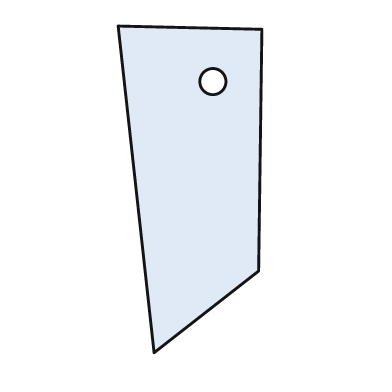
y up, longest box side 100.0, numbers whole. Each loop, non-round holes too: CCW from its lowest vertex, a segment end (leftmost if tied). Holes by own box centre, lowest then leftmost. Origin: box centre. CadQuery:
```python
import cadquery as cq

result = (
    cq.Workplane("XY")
    .moveTo(-11.0, -50.0)
    .lineTo(21.0, -25.0)
    .lineTo(22.0, 49.0)
    .lineTo(-22.0, 50.0)
    .close()
    .moveTo(7.0, 33.0)
    .circle(4.0)
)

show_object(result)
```